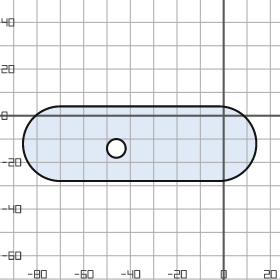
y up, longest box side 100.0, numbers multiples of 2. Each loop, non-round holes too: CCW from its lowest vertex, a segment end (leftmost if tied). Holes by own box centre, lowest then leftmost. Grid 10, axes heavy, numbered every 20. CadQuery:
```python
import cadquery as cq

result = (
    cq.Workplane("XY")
    .moveTo(-70.0, -28.0)
    .lineTo(-2.0, -28.0)
    .threePointArc((14.0, -12.0), (-2.0, 4.0))
    .lineTo(-70.0, 4.0)
    .threePointArc((-86.0, -12.0), (-70.0, -28.0))
    .close()
    .moveTo(-46.0, -14.0)
    .circle(4.0)
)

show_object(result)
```